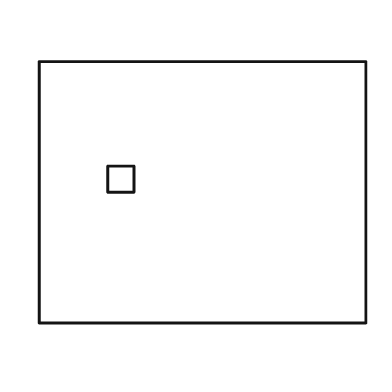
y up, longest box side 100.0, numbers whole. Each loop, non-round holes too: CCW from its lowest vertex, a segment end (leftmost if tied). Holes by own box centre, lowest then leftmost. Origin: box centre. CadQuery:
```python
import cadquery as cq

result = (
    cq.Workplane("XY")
    .moveTo(-50.0, -40.0)
    .lineTo(50.0, -40.0)
    .lineTo(50.0, 40.0)
    .lineTo(-50.0, 40.0)
    .close()
    .moveTo(-29.0, 0.0)
    .lineTo(-21.0, 0.0)
    .lineTo(-21.0, 8.0)
    .lineTo(-29.0, 8.0)
    .close()
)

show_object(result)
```